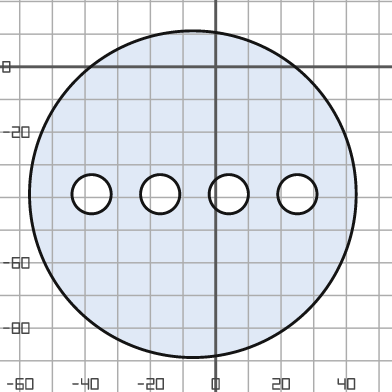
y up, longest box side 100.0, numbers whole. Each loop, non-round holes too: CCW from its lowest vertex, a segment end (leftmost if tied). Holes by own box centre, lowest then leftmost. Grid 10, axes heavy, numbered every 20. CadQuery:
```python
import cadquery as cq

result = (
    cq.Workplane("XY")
    .moveTo(-7.0, -39.0)
    .circle(50.0)
    .moveTo(-38.0, -39.0)
    .circle(6.0)
    .moveTo(-17.0, -39.0)
    .circle(6.0)
    .moveTo(4.0, -39.0)
    .circle(6.0)
    .moveTo(25.0, -39.0)
    .circle(6.0)
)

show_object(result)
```